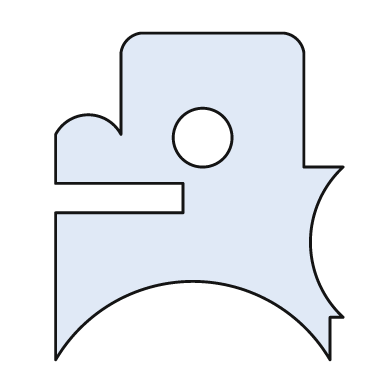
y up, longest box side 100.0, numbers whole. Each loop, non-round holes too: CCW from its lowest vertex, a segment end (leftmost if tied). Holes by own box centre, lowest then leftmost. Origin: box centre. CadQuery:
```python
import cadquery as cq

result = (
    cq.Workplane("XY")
    .moveTo(-44.0, -50.0)
    .threePointArc((-2.0, -26.0), (40.0, -50.0))
    .lineTo(40.0, -37.0)
    .lineTo(44.0, -37.0)
    .threePointArc((34.0, -14.0), (44.0, 9.0))
    .lineTo(32.0, 9.0)
    .lineTo(32.0, 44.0)
    .threePointArc((30.0, 48.0), (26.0, 50.0))
    .lineTo(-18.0, 50.0)
    .threePointArc((-22.0, 48.0), (-24.0, 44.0))
    .lineTo(-24.0, 19.0)
    .threePointArc((-34.0, 25.0), (-44.0, 19.0))
    .lineTo(-44.0, 4.0)
    .lineTo(-5.0, 4.0)
    .lineTo(-5.0, -5.0)
    .lineTo(-44.0, -5.0)
    .close()
    .moveTo(1.0, 18.0)
    .circle(9.0)
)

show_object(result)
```